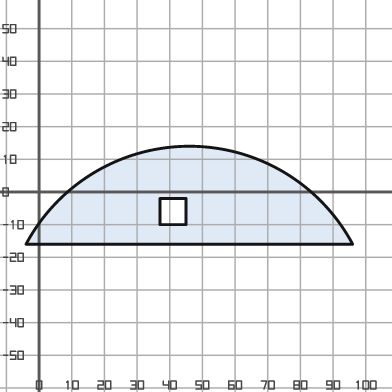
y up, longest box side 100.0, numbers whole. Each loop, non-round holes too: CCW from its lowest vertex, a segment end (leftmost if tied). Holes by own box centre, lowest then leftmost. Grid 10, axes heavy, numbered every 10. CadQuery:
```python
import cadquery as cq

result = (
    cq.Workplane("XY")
    .moveTo(-4.0, -16.0)
    .lineTo(96.0, -16.0)
    .threePointArc((46.0, 14.0), (-4.0, -16.0))
    .close()
    .moveTo(37.0, -10.0)
    .lineTo(45.0, -10.0)
    .lineTo(45.0, -2.0)
    .lineTo(37.0, -2.0)
    .close()
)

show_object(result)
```